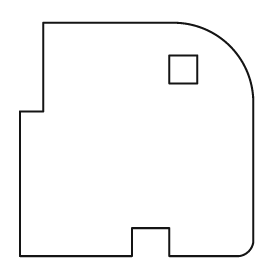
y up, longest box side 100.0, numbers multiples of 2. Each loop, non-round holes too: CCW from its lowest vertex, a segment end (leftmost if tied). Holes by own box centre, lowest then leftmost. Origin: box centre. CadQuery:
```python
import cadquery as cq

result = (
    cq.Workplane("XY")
    .moveTo(-50.0, -50.0)
    .lineTo(-2.0, -50.0)
    .lineTo(-2.0, -38.0)
    .lineTo(14.0, -38.0)
    .lineTo(14.0, -50.0)
    .lineTo(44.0, -50.0)
    .threePointArc((48.0, -48.0), (50.0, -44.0))
    .lineTo(50.0, 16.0)
    .threePointArc((40.0, 40.0), (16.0, 50.0))
    .lineTo(-40.0, 50.0)
    .lineTo(-40.0, 12.0)
    .lineTo(-50.0, 12.0)
    .close()
    .moveTo(14.0, 24.0)
    .lineTo(26.0, 24.0)
    .lineTo(26.0, 36.0)
    .lineTo(14.0, 36.0)
    .close()
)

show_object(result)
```